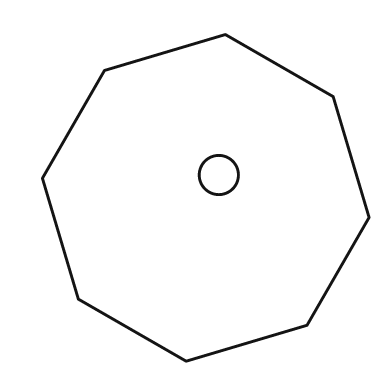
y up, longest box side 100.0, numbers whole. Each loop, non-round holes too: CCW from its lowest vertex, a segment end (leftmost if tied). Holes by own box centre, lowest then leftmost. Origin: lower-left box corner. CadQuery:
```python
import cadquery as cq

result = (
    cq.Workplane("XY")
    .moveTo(44.0, 0.0)
    .lineTo(81.0, 11.0)
    .lineTo(100.0, 44.0)
    .lineTo(89.0, 81.0)
    .lineTo(56.0, 100.0)
    .lineTo(19.0, 89.0)
    .lineTo(0.0, 56.0)
    .lineTo(11.0, 19.0)
    .close()
    .moveTo(54.0, 57.0)
    .circle(6.0)
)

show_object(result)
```